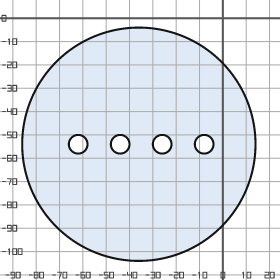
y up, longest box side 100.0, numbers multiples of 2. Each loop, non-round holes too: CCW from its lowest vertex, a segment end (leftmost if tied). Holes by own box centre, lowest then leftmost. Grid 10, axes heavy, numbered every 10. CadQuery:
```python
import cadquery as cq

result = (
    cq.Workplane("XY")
    .moveTo(-36.0, -54.0)
    .circle(50.0)
    .moveTo(-62.0, -54.0)
    .circle(4.0)
    .moveTo(-44.0, -54.0)
    .circle(4.0)
    .moveTo(-26.0, -54.0)
    .circle(4.0)
    .moveTo(-8.0, -54.0)
    .circle(4.0)
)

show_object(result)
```